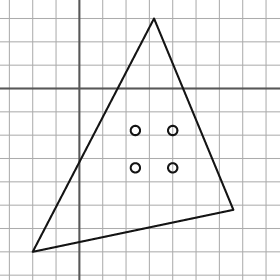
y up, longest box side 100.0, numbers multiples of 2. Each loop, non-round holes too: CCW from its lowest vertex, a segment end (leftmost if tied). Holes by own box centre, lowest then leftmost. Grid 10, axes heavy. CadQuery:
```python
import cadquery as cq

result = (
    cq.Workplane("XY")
    .moveTo(-20.0, -70.0)
    .lineTo(66.0, -52.0)
    .lineTo(32.0, 30.0)
    .close()
    .moveTo(24.0, -34.0)
    .circle(2.0)
    .moveTo(40.0, -34.0)
    .circle(2.0)
    .moveTo(24.0, -18.0)
    .circle(2.0)
    .moveTo(40.0, -18.0)
    .circle(2.0)
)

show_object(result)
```